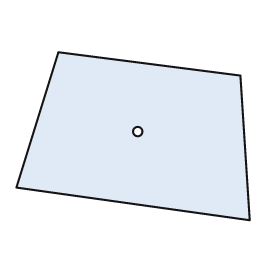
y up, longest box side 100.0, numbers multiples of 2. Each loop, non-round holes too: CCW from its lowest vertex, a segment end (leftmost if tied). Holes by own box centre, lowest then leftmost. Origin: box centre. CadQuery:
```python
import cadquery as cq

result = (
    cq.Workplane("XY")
    .moveTo(50.0, -36.0)
    .lineTo(46.0, 26.0)
    .lineTo(-32.0, 36.0)
    .lineTo(-50.0, -22.0)
    .close()
    .moveTo(2.0, 2.0)
    .circle(2.0)
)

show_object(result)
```